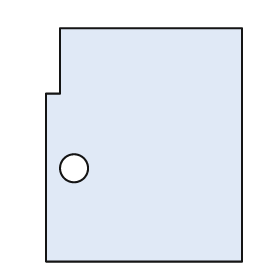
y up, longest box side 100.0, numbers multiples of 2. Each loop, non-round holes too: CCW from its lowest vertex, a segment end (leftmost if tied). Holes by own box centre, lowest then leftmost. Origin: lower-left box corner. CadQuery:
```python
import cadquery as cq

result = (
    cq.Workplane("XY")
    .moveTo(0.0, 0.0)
    .lineTo(84.0, 0.0)
    .lineTo(84.0, 100.0)
    .lineTo(6.0, 100.0)
    .lineTo(6.0, 72.0)
    .lineTo(0.0, 72.0)
    .close()
    .moveTo(12.0, 40.0)
    .circle(6.0)
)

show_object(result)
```